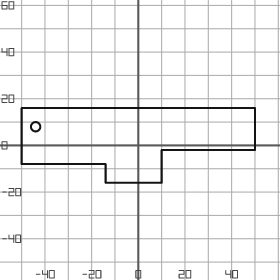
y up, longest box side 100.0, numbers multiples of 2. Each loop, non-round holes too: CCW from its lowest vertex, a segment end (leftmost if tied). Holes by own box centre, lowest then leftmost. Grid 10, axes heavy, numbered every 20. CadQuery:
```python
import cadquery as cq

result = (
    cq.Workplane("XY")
    .moveTo(-14.0, -16.0)
    .lineTo(10.0, -16.0)
    .lineTo(10.0, -2.0)
    .lineTo(50.0, -2.0)
    .lineTo(50.0, 16.0)
    .lineTo(-50.0, 16.0)
    .lineTo(-50.0, -8.0)
    .lineTo(-14.0, -8.0)
    .close()
    .moveTo(-44.0, 8.0)
    .circle(2.0)
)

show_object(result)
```